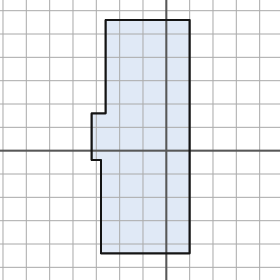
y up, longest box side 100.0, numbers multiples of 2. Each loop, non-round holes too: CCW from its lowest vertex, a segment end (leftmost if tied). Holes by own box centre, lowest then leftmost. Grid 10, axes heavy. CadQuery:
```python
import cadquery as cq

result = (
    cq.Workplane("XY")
    .moveTo(-28.0, -44.0)
    .lineTo(10.0, -44.0)
    .lineTo(10.0, 56.0)
    .lineTo(-26.0, 56.0)
    .lineTo(-26.0, 16.0)
    .lineTo(-32.0, 16.0)
    .lineTo(-32.0, -4.0)
    .lineTo(-28.0, -4.0)
    .close()
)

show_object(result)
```